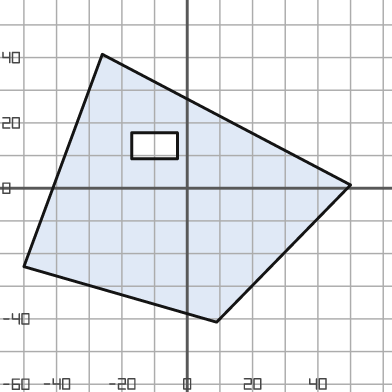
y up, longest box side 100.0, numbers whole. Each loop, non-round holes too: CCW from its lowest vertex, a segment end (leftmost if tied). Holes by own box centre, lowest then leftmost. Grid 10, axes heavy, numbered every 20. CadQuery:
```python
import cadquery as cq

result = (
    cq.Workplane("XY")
    .moveTo(9.0, -41.0)
    .lineTo(50.0, 1.0)
    .lineTo(-26.0, 41.0)
    .lineTo(-50.0, -24.0)
    .close()
    .moveTo(-17.0, 9.0)
    .lineTo(-3.0, 9.0)
    .lineTo(-3.0, 17.0)
    .lineTo(-17.0, 17.0)
    .close()
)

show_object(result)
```